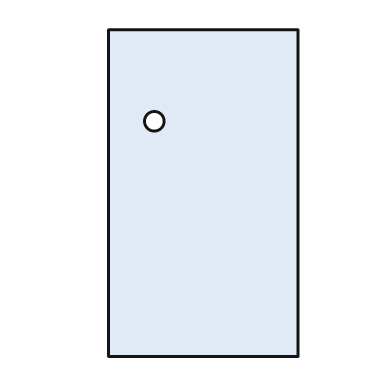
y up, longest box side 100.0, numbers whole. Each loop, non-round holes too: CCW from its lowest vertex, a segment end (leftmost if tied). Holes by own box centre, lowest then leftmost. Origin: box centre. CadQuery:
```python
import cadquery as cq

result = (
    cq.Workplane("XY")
    .moveTo(-29.0, -50.0)
    .lineTo(29.0, -50.0)
    .lineTo(29.0, 50.0)
    .lineTo(-29.0, 50.0)
    .close()
    .moveTo(-15.0, 22.0)
    .circle(3.0)
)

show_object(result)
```